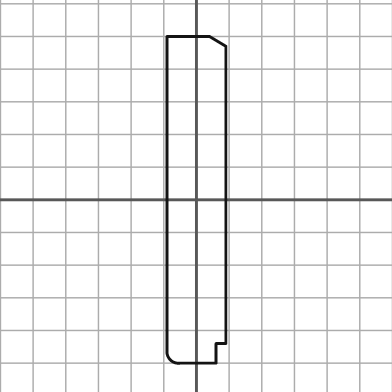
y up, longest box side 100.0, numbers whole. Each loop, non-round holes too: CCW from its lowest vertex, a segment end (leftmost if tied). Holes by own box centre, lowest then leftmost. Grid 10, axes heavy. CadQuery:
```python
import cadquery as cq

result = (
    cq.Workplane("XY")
    .moveTo(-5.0, -50.0)
    .lineTo(6.0, -50.0)
    .lineTo(6.0, -44.0)
    .lineTo(9.0, -44.0)
    .lineTo(9.0, 47.0)
    .lineTo(4.0, 50.0)
    .lineTo(-9.0, 50.0)
    .lineTo(-9.0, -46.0)
    .threePointArc((-8.0, -49.0), (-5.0, -50.0))
    .close()
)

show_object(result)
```